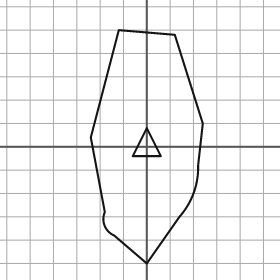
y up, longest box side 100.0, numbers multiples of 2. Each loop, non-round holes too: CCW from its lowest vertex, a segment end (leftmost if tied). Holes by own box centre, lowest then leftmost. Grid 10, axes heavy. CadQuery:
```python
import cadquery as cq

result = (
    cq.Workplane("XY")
    .moveTo(0.0, -50.0)
    .lineTo(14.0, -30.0)
    .threePointArc((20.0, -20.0), (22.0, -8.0))
    .lineTo(24.0, 10.0)
    .lineTo(12.0, 48.0)
    .lineTo(-12.0, 50.0)
    .lineTo(-24.0, 4.0)
    .lineTo(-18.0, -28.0)
    .threePointArc((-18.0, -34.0), (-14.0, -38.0))
    .close()
    .moveTo(-6.0, -4.0)
    .lineTo(6.0, -4.0)
    .lineTo(0.0, 8.0)
    .close()
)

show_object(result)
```